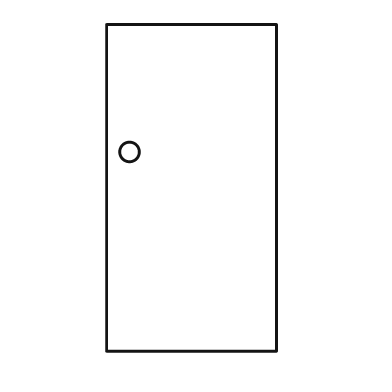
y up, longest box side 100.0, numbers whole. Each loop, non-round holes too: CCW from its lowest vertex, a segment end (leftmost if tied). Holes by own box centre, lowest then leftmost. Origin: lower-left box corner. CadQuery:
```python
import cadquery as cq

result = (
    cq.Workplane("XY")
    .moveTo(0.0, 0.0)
    .lineTo(52.0, 0.0)
    .lineTo(52.0, 100.0)
    .lineTo(0.0, 100.0)
    .close()
    .moveTo(7.0, 61.0)
    .circle(3.0)
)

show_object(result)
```